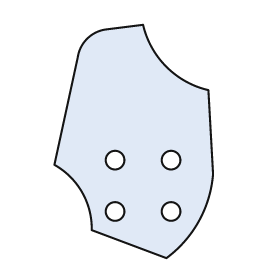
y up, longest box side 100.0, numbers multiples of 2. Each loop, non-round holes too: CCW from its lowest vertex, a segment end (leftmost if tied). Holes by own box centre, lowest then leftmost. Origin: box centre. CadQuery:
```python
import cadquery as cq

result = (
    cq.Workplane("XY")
    .moveTo(14.0, -50.0)
    .threePointArc((28.0, -34.0), (34.0, -14.0))
    .lineTo(32.0, 22.0)
    .threePointArc((14.0, 32.0), (4.0, 50.0))
    .lineTo(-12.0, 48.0)
    .threePointArc((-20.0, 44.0), (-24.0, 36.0))
    .lineTo(-34.0, -10.0)
    .threePointArc((-22.0, -22.0), (-18.0, -38.0))
    .close()
    .moveTo(-8.0, -30.0)
    .circle(4.0)
    .moveTo(16.0, -30.0)
    .circle(4.0)
    .moveTo(-8.0, -8.0)
    .circle(4.0)
    .moveTo(16.0, -8.0)
    .circle(4.0)
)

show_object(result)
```